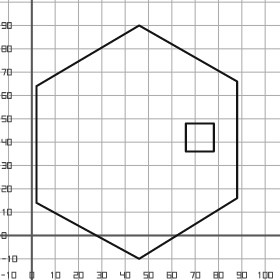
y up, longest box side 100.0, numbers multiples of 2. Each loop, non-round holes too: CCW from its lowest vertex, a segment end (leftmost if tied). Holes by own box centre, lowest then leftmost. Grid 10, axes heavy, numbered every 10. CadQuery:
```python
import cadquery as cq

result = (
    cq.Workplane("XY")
    .moveTo(46.0, -10.0)
    .lineTo(88.0, 16.0)
    .lineTo(88.0, 66.0)
    .lineTo(46.0, 90.0)
    .lineTo(2.0, 64.0)
    .lineTo(2.0, 14.0)
    .close()
    .moveTo(66.0, 36.0)
    .lineTo(78.0, 36.0)
    .lineTo(78.0, 48.0)
    .lineTo(66.0, 48.0)
    .close()
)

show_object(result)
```